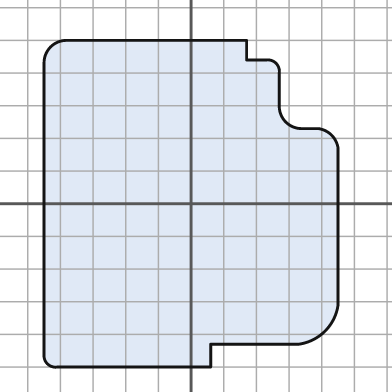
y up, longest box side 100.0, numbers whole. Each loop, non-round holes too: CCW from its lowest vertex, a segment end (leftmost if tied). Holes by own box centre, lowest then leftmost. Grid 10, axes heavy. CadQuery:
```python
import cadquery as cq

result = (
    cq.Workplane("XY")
    .moveTo(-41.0, -50.0)
    .lineTo(6.0, -50.0)
    .lineTo(6.0, -43.0)
    .lineTo(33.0, -43.0)
    .threePointArc((41.0, -39.0), (45.0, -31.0))
    .lineTo(45.0, 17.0)
    .threePointArc((43.0, 21.0), (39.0, 23.0))
    .lineTo(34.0, 23.0)
    .threePointArc((29.0, 25.0), (27.0, 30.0))
    .lineTo(27.0, 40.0)
    .threePointArc((26.0, 43.0), (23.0, 44.0))
    .lineTo(17.0, 44.0)
    .lineTo(17.0, 50.0)
    .lineTo(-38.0, 50.0)
    .threePointArc((-43.0, 48.0), (-45.0, 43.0))
    .lineTo(-45.0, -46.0)
    .threePointArc((-44.0, -49.0), (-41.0, -50.0))
    .close()
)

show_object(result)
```